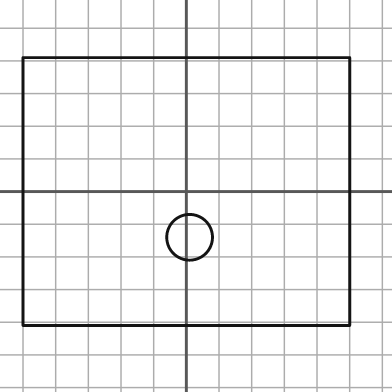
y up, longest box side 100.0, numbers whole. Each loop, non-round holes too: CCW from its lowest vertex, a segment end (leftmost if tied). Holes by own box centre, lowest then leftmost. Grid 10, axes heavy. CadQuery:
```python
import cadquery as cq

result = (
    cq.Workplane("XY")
    .moveTo(-50.0, -41.0)
    .lineTo(50.0, -41.0)
    .lineTo(50.0, 41.0)
    .lineTo(-50.0, 41.0)
    .close()
    .moveTo(1.0, -14.0)
    .circle(7.0)
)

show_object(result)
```